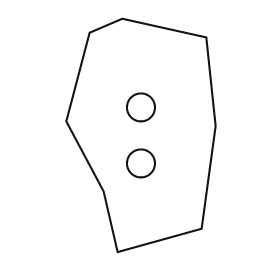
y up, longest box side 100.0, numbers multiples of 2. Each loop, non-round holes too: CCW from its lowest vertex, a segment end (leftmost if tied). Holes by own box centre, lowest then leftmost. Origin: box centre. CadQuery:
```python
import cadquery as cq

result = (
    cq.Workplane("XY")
    .moveTo(-10.0, -50.0)
    .lineTo(26.0, -40.0)
    .lineTo(32.0, 4.0)
    .lineTo(28.0, 42.0)
    .lineTo(-8.0, 50.0)
    .lineTo(-22.0, 44.0)
    .lineTo(-32.0, 6.0)
    .lineTo(-16.0, -24.0)
    .close()
    .moveTo(0.0, -12.0)
    .circle(6.0)
    .moveTo(0.0, 12.0)
    .circle(6.0)
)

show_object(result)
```